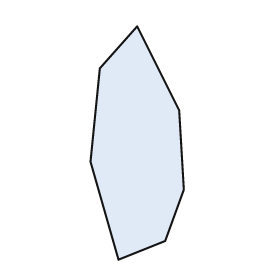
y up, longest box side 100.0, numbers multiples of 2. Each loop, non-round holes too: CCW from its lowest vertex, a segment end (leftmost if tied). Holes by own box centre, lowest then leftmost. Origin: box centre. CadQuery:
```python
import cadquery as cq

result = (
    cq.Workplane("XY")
    .moveTo(-8.0, -50.0)
    .lineTo(12.0, -42.0)
    .lineTo(20.0, -20.0)
    .lineTo(18.0, 14.0)
    .lineTo(0.0, 50.0)
    .lineTo(-16.0, 32.0)
    .lineTo(-20.0, -8.0)
    .close()
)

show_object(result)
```